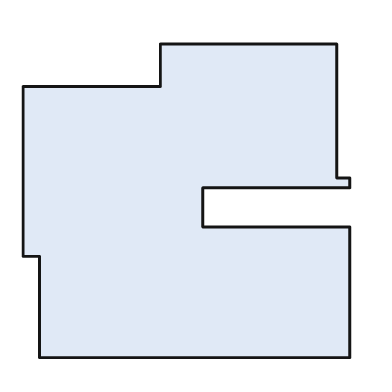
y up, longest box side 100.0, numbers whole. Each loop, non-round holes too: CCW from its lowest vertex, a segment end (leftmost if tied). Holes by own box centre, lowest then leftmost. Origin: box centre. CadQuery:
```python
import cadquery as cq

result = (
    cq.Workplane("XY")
    .moveTo(-45.0, -48.0)
    .lineTo(50.0, -48.0)
    .lineTo(50.0, -8.0)
    .lineTo(5.0, -8.0)
    .lineTo(5.0, 4.0)
    .lineTo(50.0, 4.0)
    .lineTo(50.0, 7.0)
    .lineTo(46.0, 7.0)
    .lineTo(46.0, 48.0)
    .lineTo(-8.0, 48.0)
    .lineTo(-8.0, 35.0)
    .lineTo(-50.0, 35.0)
    .lineTo(-50.0, -17.0)
    .lineTo(-45.0, -17.0)
    .close()
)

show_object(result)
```